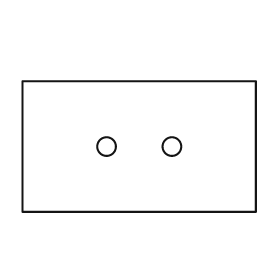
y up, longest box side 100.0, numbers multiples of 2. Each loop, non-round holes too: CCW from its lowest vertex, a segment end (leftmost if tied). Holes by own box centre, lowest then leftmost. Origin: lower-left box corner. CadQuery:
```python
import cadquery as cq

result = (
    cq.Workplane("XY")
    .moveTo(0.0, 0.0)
    .lineTo(100.0, 0.0)
    .lineTo(100.0, 56.0)
    .lineTo(0.0, 56.0)
    .close()
    .moveTo(36.0, 28.0)
    .circle(4.0)
    .moveTo(64.0, 28.0)
    .circle(4.0)
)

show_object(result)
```